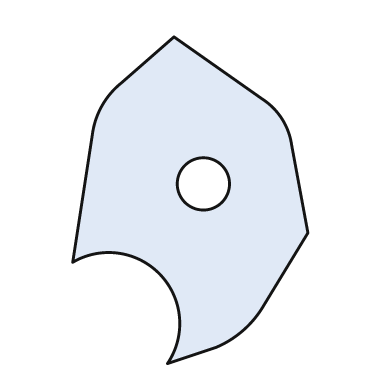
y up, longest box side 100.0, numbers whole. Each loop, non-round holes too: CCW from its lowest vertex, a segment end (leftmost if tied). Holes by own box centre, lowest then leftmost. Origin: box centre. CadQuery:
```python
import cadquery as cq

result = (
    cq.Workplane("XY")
    .moveTo(-7.0, -50.0)
    .lineTo(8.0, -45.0)
    .threePointArc((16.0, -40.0), (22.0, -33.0))
    .lineTo(36.0, -10.0)
    .lineTo(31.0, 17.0)
    .threePointArc((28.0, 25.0), (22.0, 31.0))
    .lineTo(-5.0, 50.0)
    .lineTo(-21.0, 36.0)
    .threePointArc((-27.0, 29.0), (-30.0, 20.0))
    .lineTo(-36.0, -19.0)
    .threePointArc((-9.0, -23.0), (-7.0, -50.0))
    .close()
    .moveTo(4.0, 5.0)
    .circle(8.0)
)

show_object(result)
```